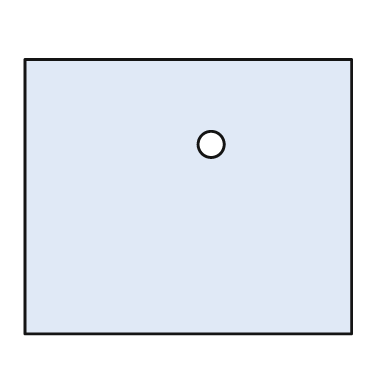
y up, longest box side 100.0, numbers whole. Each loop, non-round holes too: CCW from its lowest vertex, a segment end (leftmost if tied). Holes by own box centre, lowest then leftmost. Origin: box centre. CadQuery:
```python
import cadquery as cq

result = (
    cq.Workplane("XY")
    .moveTo(-50.0, -42.0)
    .lineTo(50.0, -42.0)
    .lineTo(50.0, 42.0)
    .lineTo(-50.0, 42.0)
    .close()
    .moveTo(7.0, 16.0)
    .circle(4.0)
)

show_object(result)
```